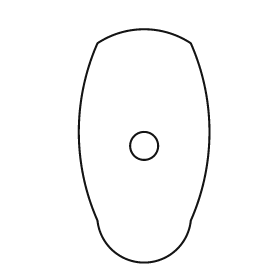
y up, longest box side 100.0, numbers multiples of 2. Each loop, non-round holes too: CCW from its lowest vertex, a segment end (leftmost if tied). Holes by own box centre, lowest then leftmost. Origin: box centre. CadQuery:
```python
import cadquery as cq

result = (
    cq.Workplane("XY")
    .moveTo(-20.0, -32.0)
    .threePointArc((0.0, -50.0), (20.0, -32.0))
    .threePointArc((28.0, 6.0), (20.0, 44.0))
    .threePointArc((0.0, 50.0), (-20.0, 44.0))
    .threePointArc((-28.0, 6.0), (-20.0, -32.0))
    .close()
    .moveTo(0.0, 0.0)
    .circle(6.0)
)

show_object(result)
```